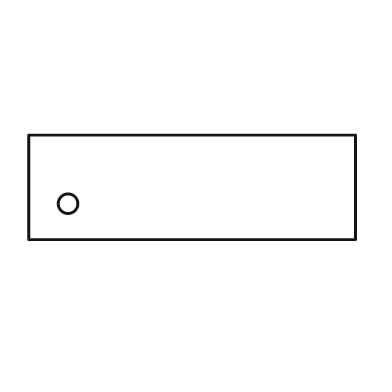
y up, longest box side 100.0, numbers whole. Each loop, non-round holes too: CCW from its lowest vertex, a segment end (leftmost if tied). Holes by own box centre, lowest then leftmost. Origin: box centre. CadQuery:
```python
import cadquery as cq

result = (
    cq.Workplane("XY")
    .moveTo(-50.0, -16.0)
    .lineTo(50.0, -16.0)
    .lineTo(50.0, 16.0)
    .lineTo(-50.0, 16.0)
    .close()
    .moveTo(-38.0, -5.0)
    .circle(3.0)
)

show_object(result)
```